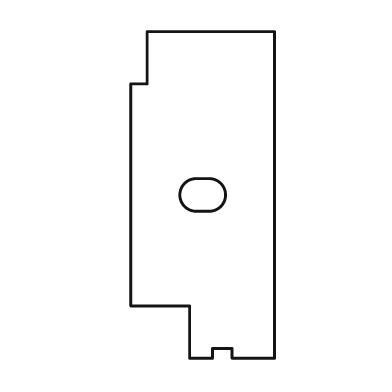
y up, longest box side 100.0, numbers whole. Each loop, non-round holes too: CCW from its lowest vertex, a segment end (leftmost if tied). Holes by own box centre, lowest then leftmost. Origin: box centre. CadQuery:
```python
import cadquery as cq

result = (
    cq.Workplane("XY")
    .moveTo(-4.0, -50.0)
    .lineTo(3.0, -50.0)
    .lineTo(3.0, -47.0)
    .lineTo(9.0, -47.0)
    .lineTo(9.0, -50.0)
    .lineTo(22.0, -50.0)
    .lineTo(22.0, 50.0)
    .lineTo(-17.0, 50.0)
    .lineTo(-17.0, 34.0)
    .lineTo(-22.0, 34.0)
    .lineTo(-22.0, -34.0)
    .lineTo(-4.0, -34.0)
    .close()
    .moveTo(-2.0, -5.0)
    .lineTo(2.0, -5.0)
    .threePointArc((7.0, 0.0), (2.0, 5.0))
    .lineTo(-2.0, 5.0)
    .threePointArc((-7.0, 0.0), (-2.0, -5.0))
    .close()
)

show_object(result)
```